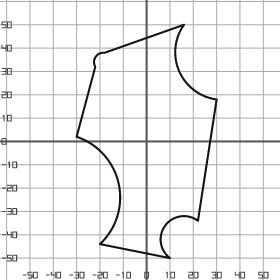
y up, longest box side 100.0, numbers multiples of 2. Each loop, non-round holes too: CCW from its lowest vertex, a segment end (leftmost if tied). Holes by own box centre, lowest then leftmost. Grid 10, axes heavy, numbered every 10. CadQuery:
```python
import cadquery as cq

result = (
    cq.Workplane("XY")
    .moveTo(10.0, -50.0)
    .threePointArc((8.0, -36.0), (22.0, -34.0))
    .lineTo(30.0, 18.0)
    .threePointArc((14.0, 30.0), (16.0, 50.0))
    .lineTo(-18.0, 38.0)
    .threePointArc((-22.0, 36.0), (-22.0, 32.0))
    .lineTo(-30.0, 2.0)
    .threePointArc((-12.0, -18.0), (-20.0, -44.0))
    .close()
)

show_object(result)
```